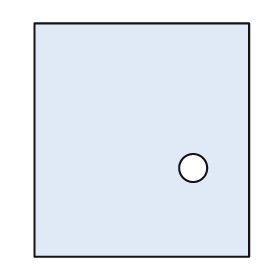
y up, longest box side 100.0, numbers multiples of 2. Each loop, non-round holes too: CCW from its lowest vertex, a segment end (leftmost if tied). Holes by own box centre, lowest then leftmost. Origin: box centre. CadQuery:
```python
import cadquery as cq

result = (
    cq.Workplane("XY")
    .moveTo(-46.0, -50.0)
    .lineTo(46.0, -50.0)
    .lineTo(46.0, 50.0)
    .lineTo(-46.0, 50.0)
    .close()
    .moveTo(22.0, -12.0)
    .circle(6.0)
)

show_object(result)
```